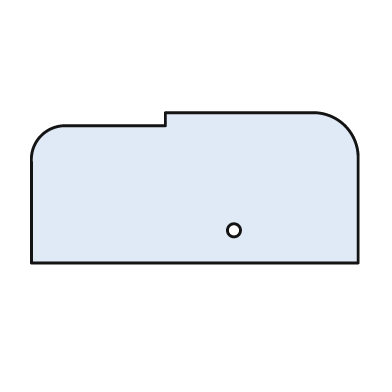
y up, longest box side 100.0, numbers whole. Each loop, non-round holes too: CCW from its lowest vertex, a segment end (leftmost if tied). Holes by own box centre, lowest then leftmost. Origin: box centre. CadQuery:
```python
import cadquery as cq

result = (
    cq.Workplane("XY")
    .moveTo(-50.0, -23.0)
    .lineTo(50.0, -23.0)
    .lineTo(50.0, 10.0)
    .threePointArc((46.0, 19.0), (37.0, 23.0))
    .lineTo(-9.0, 23.0)
    .lineTo(-9.0, 19.0)
    .lineTo(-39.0, 19.0)
    .threePointArc((-47.0, 16.0), (-50.0, 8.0))
    .close()
    .moveTo(12.0, -13.0)
    .circle(2.0)
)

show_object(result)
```